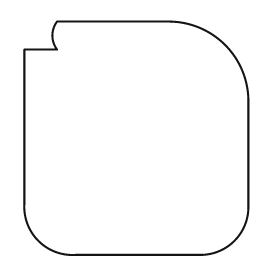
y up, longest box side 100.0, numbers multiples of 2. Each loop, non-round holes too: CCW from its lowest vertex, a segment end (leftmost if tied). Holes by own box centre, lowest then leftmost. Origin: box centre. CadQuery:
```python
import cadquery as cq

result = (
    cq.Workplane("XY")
    .moveTo(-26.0, -50.0)
    .lineTo(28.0, -50.0)
    .threePointArc((42.0, -44.0), (48.0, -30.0))
    .lineTo(48.0, 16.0)
    .threePointArc((38.0, 40.0), (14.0, 50.0))
    .lineTo(-34.0, 50.0)
    .threePointArc((-36.0, 44.0), (-34.0, 38.0))
    .lineTo(-48.0, 38.0)
    .lineTo(-48.0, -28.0)
    .threePointArc((-42.0, -44.0), (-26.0, -50.0))
    .close()
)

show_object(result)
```